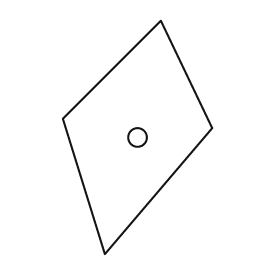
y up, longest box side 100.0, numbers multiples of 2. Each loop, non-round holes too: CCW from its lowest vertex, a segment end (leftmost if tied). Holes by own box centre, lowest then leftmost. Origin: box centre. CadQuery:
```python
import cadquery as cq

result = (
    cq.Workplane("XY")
    .moveTo(-14.0, -50.0)
    .lineTo(32.0, 4.0)
    .lineTo(10.0, 50.0)
    .lineTo(-32.0, 8.0)
    .close()
    .moveTo(0.0, 0.0)
    .circle(4.0)
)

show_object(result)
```